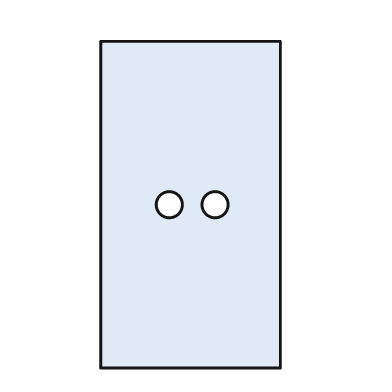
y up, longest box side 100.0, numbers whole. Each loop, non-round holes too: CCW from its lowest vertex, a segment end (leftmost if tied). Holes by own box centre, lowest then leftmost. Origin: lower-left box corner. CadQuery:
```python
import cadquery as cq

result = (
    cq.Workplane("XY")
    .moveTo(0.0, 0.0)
    .lineTo(55.0, 0.0)
    .lineTo(55.0, 100.0)
    .lineTo(0.0, 100.0)
    .close()
    .moveTo(21.0, 50.0)
    .circle(4.0)
    .moveTo(35.0, 50.0)
    .circle(4.0)
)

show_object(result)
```